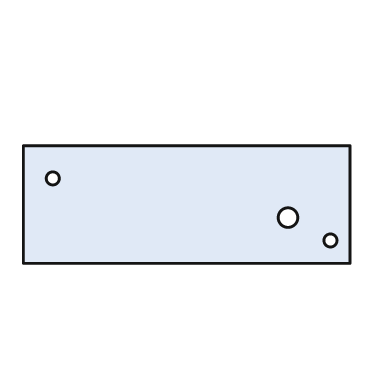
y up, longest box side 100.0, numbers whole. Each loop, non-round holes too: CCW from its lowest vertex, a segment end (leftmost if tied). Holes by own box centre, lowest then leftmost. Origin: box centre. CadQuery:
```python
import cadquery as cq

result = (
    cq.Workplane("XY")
    .moveTo(-50.0, -18.0)
    .lineTo(50.0, -18.0)
    .lineTo(50.0, 18.0)
    .lineTo(-50.0, 18.0)
    .close()
    .moveTo(44.0, -11.0)
    .circle(2.0)
    .moveTo(31.0, -4.0)
    .circle(3.0)
    .moveTo(-41.0, 8.0)
    .circle(2.0)
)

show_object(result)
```